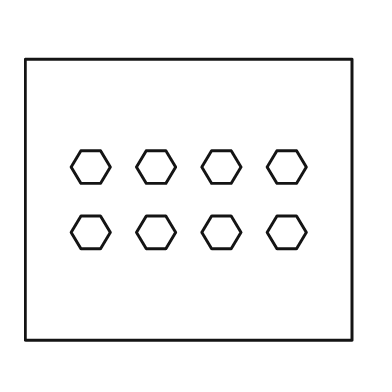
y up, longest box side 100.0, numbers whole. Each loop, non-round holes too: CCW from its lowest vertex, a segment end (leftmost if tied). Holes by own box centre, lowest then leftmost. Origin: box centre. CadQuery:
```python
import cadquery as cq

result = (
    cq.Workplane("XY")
    .moveTo(-50.0, -43.0)
    .lineTo(50.0, -43.0)
    .lineTo(50.0, 43.0)
    .lineTo(-50.0, 43.0)
    .close()
    .moveTo(-33.0, -15.0)
    .lineTo(-27.0, -15.0)
    .lineTo(-24.0, -10.0)
    .lineTo(-27.0, -5.0)
    .lineTo(-33.0, -5.0)
    .lineTo(-36.0, -10.0)
    .close()
    .moveTo(-13.0, -15.0)
    .lineTo(-7.0, -15.0)
    .lineTo(-4.0, -10.0)
    .lineTo(-7.0, -5.0)
    .lineTo(-13.0, -5.0)
    .lineTo(-16.0, -10.0)
    .close()
    .moveTo(7.0, -15.0)
    .lineTo(13.0, -15.0)
    .lineTo(16.0, -10.0)
    .lineTo(13.0, -5.0)
    .lineTo(7.0, -5.0)
    .lineTo(4.0, -10.0)
    .close()
    .moveTo(27.0, -15.0)
    .lineTo(33.0, -15.0)
    .lineTo(36.0, -10.0)
    .lineTo(33.0, -5.0)
    .lineTo(27.0, -5.0)
    .lineTo(24.0, -10.0)
    .close()
    .moveTo(-33.0, 5.0)
    .lineTo(-27.0, 5.0)
    .lineTo(-24.0, 10.0)
    .lineTo(-27.0, 15.0)
    .lineTo(-33.0, 15.0)
    .lineTo(-36.0, 10.0)
    .close()
    .moveTo(-13.0, 5.0)
    .lineTo(-7.0, 5.0)
    .lineTo(-4.0, 10.0)
    .lineTo(-7.0, 15.0)
    .lineTo(-13.0, 15.0)
    .lineTo(-16.0, 10.0)
    .close()
    .moveTo(7.0, 5.0)
    .lineTo(13.0, 5.0)
    .lineTo(16.0, 10.0)
    .lineTo(13.0, 15.0)
    .lineTo(7.0, 15.0)
    .lineTo(4.0, 10.0)
    .close()
    .moveTo(27.0, 5.0)
    .lineTo(33.0, 5.0)
    .lineTo(36.0, 10.0)
    .lineTo(33.0, 15.0)
    .lineTo(27.0, 15.0)
    .lineTo(24.0, 10.0)
    .close()
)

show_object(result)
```